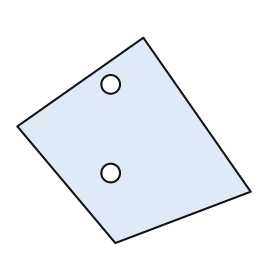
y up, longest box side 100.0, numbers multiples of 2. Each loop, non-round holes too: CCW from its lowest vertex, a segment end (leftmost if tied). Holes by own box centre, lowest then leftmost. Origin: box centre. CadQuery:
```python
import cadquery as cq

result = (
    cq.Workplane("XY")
    .moveTo(-8.0, -44.0)
    .lineTo(50.0, -22.0)
    .lineTo(4.0, 44.0)
    .lineTo(-50.0, 6.0)
    .close()
    .moveTo(-10.0, -14.0)
    .circle(4.0)
    .moveTo(-10.0, 24.0)
    .circle(4.0)
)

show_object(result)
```